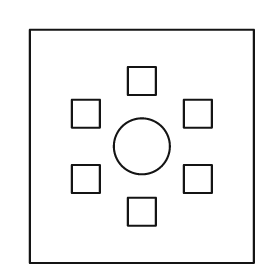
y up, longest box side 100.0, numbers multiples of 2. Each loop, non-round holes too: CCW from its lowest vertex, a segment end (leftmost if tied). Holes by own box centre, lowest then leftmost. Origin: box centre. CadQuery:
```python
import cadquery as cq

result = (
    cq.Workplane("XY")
    .moveTo(-48.0, -50.0)
    .lineTo(48.0, -50.0)
    .lineTo(48.0, 50.0)
    .lineTo(-48.0, 50.0)
    .close()
    .moveTo(-6.0, -34.0)
    .lineTo(6.0, -34.0)
    .lineTo(6.0, -22.0)
    .lineTo(-6.0, -22.0)
    .close()
    .moveTo(-30.0, -20.0)
    .lineTo(-18.0, -20.0)
    .lineTo(-18.0, -8.0)
    .lineTo(-30.0, -8.0)
    .close()
    .moveTo(18.0, -20.0)
    .lineTo(30.0, -20.0)
    .lineTo(30.0, -8.0)
    .lineTo(18.0, -8.0)
    .close()
    .moveTo(0.0, 0.0)
    .circle(12.0)
    .moveTo(-30.0, 8.0)
    .lineTo(-18.0, 8.0)
    .lineTo(-18.0, 20.0)
    .lineTo(-30.0, 20.0)
    .close()
    .moveTo(18.0, 8.0)
    .lineTo(30.0, 8.0)
    .lineTo(30.0, 20.0)
    .lineTo(18.0, 20.0)
    .close()
    .moveTo(-6.0, 22.0)
    .lineTo(6.0, 22.0)
    .lineTo(6.0, 34.0)
    .lineTo(-6.0, 34.0)
    .close()
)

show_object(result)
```